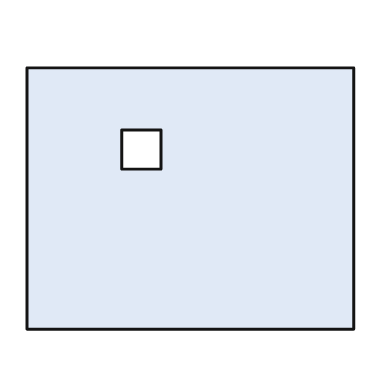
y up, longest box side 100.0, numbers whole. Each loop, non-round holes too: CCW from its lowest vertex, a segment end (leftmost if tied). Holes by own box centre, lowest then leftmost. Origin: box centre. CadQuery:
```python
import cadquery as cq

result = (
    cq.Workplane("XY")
    .moveTo(-50.0, -40.0)
    .lineTo(50.0, -40.0)
    .lineTo(50.0, 40.0)
    .lineTo(-50.0, 40.0)
    .close()
    .moveTo(-21.0, 9.0)
    .lineTo(-9.0, 9.0)
    .lineTo(-9.0, 21.0)
    .lineTo(-21.0, 21.0)
    .close()
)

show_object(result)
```